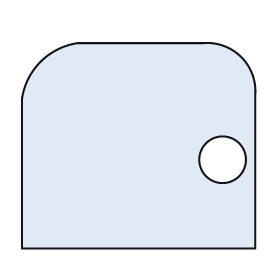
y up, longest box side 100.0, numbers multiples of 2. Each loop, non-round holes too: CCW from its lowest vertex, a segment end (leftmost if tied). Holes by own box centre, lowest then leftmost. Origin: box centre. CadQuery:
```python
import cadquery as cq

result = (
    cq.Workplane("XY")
    .moveTo(-50.0, -44.0)
    .lineTo(50.0, -44.0)
    .lineTo(50.0, 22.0)
    .threePointArc((44.0, 38.0), (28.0, 44.0))
    .lineTo(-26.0, 44.0)
    .threePointArc((-42.0, 36.0), (-50.0, 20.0))
    .close()
    .moveTo(36.0, -6.0)
    .circle(10.0)
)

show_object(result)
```